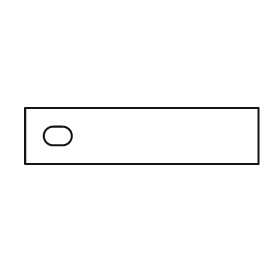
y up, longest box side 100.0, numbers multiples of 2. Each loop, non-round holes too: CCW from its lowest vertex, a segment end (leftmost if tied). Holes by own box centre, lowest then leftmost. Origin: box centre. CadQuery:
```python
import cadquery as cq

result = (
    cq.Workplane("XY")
    .moveTo(-50.0, -12.0)
    .lineTo(50.0, -12.0)
    .lineTo(50.0, 12.0)
    .lineTo(-50.0, 12.0)
    .close()
    .moveTo(-38.0, -4.0)
    .lineTo(-34.0, -4.0)
    .threePointArc((-30.0, 0.0), (-34.0, 4.0))
    .lineTo(-38.0, 4.0)
    .threePointArc((-42.0, 0.0), (-38.0, -4.0))
    .close()
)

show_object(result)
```